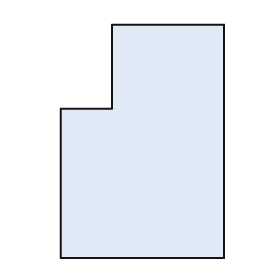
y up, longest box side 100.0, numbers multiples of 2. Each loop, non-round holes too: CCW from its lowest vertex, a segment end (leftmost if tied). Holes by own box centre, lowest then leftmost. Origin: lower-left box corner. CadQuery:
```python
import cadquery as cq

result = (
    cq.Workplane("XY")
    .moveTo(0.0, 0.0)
    .lineTo(70.0, 0.0)
    .lineTo(70.0, 100.0)
    .lineTo(22.0, 100.0)
    .lineTo(22.0, 64.0)
    .lineTo(0.0, 64.0)
    .close()
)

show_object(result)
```